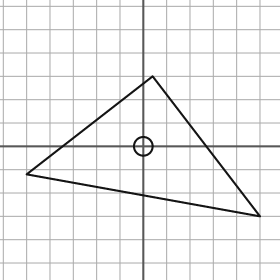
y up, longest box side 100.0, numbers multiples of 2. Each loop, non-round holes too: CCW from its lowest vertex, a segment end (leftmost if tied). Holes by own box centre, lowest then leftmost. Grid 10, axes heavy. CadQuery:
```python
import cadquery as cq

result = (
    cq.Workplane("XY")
    .moveTo(50.0, -30.0)
    .lineTo(4.0, 30.0)
    .lineTo(-50.0, -12.0)
    .close()
    .moveTo(0.0, 0.0)
    .circle(4.0)
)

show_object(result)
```